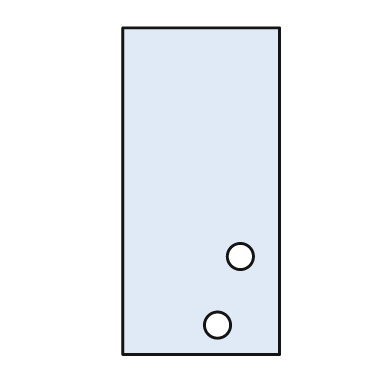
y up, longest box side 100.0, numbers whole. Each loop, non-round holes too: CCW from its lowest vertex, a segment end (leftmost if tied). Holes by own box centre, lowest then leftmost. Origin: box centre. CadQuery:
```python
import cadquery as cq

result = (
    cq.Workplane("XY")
    .moveTo(-24.0, -50.0)
    .lineTo(24.0, -50.0)
    .lineTo(24.0, 50.0)
    .lineTo(-24.0, 50.0)
    .close()
    .moveTo(5.0, -41.0)
    .circle(4.0)
    .moveTo(12.0, -20.0)
    .circle(4.0)
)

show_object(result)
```